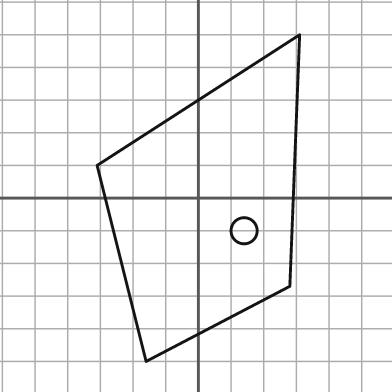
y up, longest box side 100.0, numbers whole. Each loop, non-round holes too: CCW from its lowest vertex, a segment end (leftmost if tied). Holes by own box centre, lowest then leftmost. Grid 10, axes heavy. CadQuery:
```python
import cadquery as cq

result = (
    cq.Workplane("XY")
    .moveTo(-16.0, -50.0)
    .lineTo(28.0, -27.0)
    .lineTo(31.0, 50.0)
    .lineTo(-31.0, 10.0)
    .close()
    .moveTo(14.0, -10.0)
    .circle(4.0)
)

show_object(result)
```